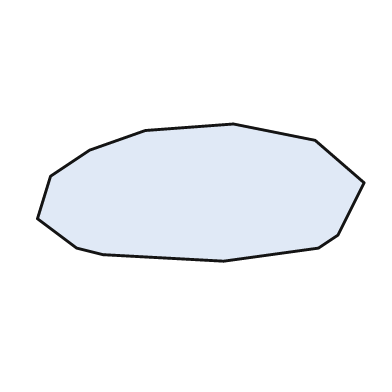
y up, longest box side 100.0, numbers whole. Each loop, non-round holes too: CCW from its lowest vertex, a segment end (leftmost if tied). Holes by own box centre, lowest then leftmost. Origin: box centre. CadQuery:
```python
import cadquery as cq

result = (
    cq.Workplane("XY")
    .moveTo(7.0, -21.0)
    .lineTo(36.0, -17.0)
    .lineTo(42.0, -13.0)
    .lineTo(50.0, 3.0)
    .lineTo(35.0, 16.0)
    .lineTo(10.0, 21.0)
    .lineTo(-17.0, 19.0)
    .lineTo(-34.0, 13.0)
    .lineTo(-46.0, 5.0)
    .lineTo(-50.0, -8.0)
    .lineTo(-38.0, -17.0)
    .lineTo(-30.0, -19.0)
    .close()
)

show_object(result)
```